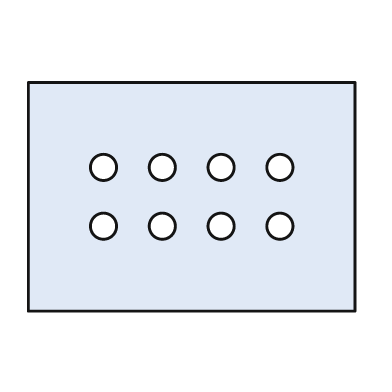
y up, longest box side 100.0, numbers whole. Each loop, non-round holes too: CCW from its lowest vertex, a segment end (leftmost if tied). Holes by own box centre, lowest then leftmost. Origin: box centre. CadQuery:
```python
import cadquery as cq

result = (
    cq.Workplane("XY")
    .moveTo(-50.0, -35.0)
    .lineTo(50.0, -35.0)
    .lineTo(50.0, 35.0)
    .lineTo(-50.0, 35.0)
    .close()
    .moveTo(-27.0, -9.0)
    .circle(4.0)
    .moveTo(-9.0, -9.0)
    .circle(4.0)
    .moveTo(9.0, -9.0)
    .circle(4.0)
    .moveTo(27.0, -9.0)
    .circle(4.0)
    .moveTo(-27.0, 9.0)
    .circle(4.0)
    .moveTo(-9.0, 9.0)
    .circle(4.0)
    .moveTo(9.0, 9.0)
    .circle(4.0)
    .moveTo(27.0, 9.0)
    .circle(4.0)
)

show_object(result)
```